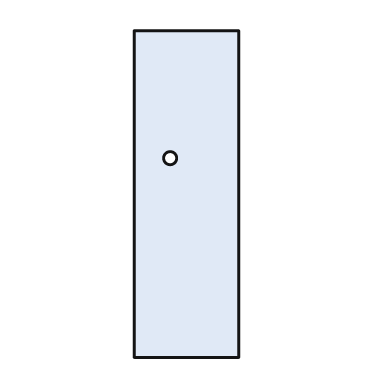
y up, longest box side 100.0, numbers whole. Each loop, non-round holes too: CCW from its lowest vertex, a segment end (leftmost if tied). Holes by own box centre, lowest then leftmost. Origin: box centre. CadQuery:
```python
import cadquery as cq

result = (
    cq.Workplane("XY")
    .moveTo(-16.0, -50.0)
    .lineTo(16.0, -50.0)
    .lineTo(16.0, 50.0)
    .lineTo(-16.0, 50.0)
    .close()
    .moveTo(-5.0, 11.0)
    .circle(2.0)
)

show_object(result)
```